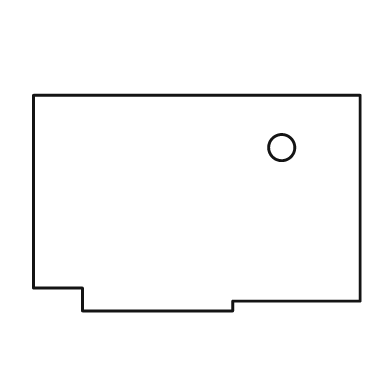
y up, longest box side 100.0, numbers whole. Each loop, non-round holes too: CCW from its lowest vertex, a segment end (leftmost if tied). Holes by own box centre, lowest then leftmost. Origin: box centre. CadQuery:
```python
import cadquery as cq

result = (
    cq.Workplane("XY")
    .moveTo(-35.0, -33.0)
    .lineTo(11.0, -33.0)
    .lineTo(11.0, -30.0)
    .lineTo(50.0, -30.0)
    .lineTo(50.0, 33.0)
    .lineTo(-50.0, 33.0)
    .lineTo(-50.0, -26.0)
    .lineTo(-35.0, -26.0)
    .close()
    .moveTo(26.0, 17.0)
    .circle(4.0)
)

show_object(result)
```